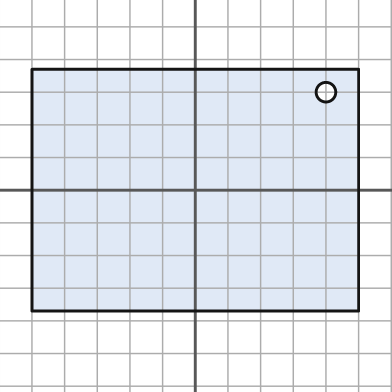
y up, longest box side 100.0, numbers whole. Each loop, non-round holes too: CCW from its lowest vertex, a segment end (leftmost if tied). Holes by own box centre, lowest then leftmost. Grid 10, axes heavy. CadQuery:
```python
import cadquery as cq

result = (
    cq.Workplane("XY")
    .moveTo(-50.0, -37.0)
    .lineTo(50.0, -37.0)
    .lineTo(50.0, 37.0)
    .lineTo(-50.0, 37.0)
    .close()
    .moveTo(40.0, 30.0)
    .circle(3.0)
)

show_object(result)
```